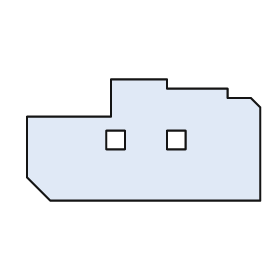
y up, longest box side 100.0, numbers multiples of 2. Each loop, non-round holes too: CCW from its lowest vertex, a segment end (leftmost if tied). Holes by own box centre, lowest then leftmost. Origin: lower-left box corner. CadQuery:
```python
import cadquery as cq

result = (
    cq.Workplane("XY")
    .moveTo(10.0, 0.0)
    .lineTo(100.0, 0.0)
    .lineTo(100.0, 40.0)
    .lineTo(96.0, 44.0)
    .lineTo(86.0, 44.0)
    .lineTo(86.0, 48.0)
    .lineTo(60.0, 48.0)
    .lineTo(60.0, 52.0)
    .lineTo(36.0, 52.0)
    .lineTo(36.0, 36.0)
    .lineTo(0.0, 36.0)
    .lineTo(0.0, 10.0)
    .close()
    .moveTo(34.0, 22.0)
    .lineTo(42.0, 22.0)
    .lineTo(42.0, 30.0)
    .lineTo(34.0, 30.0)
    .close()
    .moveTo(60.0, 22.0)
    .lineTo(68.0, 22.0)
    .lineTo(68.0, 30.0)
    .lineTo(60.0, 30.0)
    .close()
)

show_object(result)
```